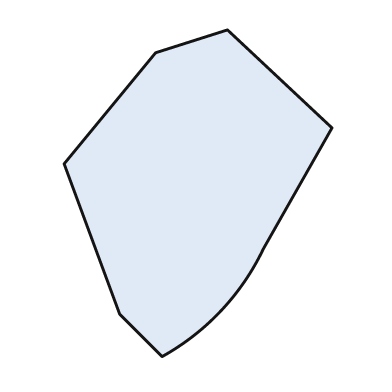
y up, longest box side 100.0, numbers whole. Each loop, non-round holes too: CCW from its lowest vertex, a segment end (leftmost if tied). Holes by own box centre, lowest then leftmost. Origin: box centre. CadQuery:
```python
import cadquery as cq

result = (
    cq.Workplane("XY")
    .moveTo(-11.0, -50.0)
    .threePointArc((7.0, -36.0), (20.0, -17.0))
    .lineTo(41.0, 20.0)
    .lineTo(9.0, 50.0)
    .lineTo(-13.0, 43.0)
    .lineTo(-41.0, 9.0)
    .lineTo(-24.0, -37.0)
    .close()
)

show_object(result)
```